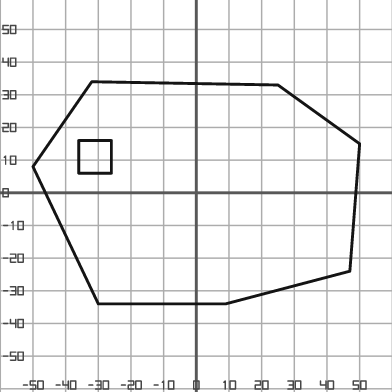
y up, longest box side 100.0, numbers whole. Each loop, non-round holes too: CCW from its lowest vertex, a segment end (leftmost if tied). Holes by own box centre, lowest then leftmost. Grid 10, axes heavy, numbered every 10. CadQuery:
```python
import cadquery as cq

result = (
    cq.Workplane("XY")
    .moveTo(-30.0, -34.0)
    .lineTo(9.0, -34.0)
    .lineTo(47.0, -24.0)
    .lineTo(50.0, 15.0)
    .lineTo(25.0, 33.0)
    .lineTo(-32.0, 34.0)
    .lineTo(-50.0, 8.0)
    .close()
    .moveTo(-36.0, 6.0)
    .lineTo(-26.0, 6.0)
    .lineTo(-26.0, 16.0)
    .lineTo(-36.0, 16.0)
    .close()
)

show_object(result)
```